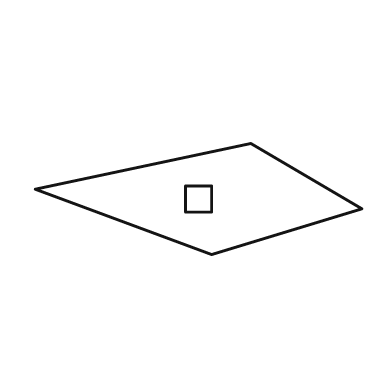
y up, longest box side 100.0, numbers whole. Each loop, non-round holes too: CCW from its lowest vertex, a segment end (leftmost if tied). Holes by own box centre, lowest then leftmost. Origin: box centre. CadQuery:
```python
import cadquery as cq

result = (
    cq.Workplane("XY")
    .moveTo(4.0, -17.0)
    .lineTo(50.0, -3.0)
    .lineTo(16.0, 17.0)
    .lineTo(-50.0, 3.0)
    .close()
    .moveTo(-4.0, -4.0)
    .lineTo(4.0, -4.0)
    .lineTo(4.0, 4.0)
    .lineTo(-4.0, 4.0)
    .close()
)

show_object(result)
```